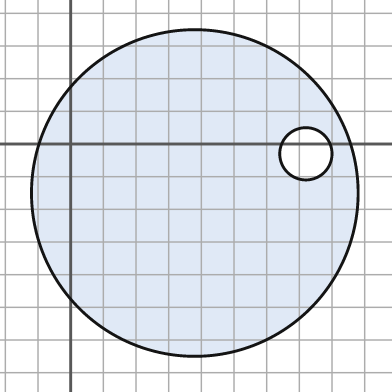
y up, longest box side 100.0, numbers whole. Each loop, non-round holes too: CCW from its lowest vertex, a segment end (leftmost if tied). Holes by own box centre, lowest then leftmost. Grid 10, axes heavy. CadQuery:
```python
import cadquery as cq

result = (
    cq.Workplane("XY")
    .moveTo(38.0, -15.0)
    .circle(50.0)
    .moveTo(72.0, -3.0)
    .circle(8.0)
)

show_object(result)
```